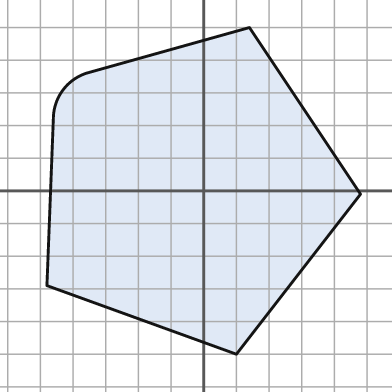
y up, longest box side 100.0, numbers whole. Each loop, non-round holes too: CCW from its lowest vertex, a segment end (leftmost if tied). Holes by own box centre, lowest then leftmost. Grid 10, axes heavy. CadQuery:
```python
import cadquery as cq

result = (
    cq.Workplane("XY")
    .moveTo(10.0, -50.0)
    .lineTo(48.0, -1.0)
    .lineTo(14.0, 50.0)
    .lineTo(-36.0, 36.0)
    .threePointArc((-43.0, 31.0), (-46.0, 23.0))
    .lineTo(-48.0, -29.0)
    .close()
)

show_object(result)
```